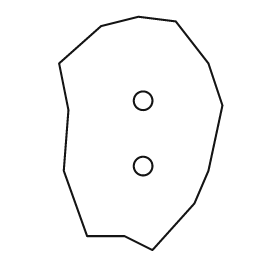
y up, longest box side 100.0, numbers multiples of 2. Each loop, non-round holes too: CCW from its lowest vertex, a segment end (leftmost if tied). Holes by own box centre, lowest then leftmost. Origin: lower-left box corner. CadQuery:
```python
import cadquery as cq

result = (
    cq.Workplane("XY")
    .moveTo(40.0, 0.0)
    .lineTo(58.0, 20.0)
    .lineTo(64.0, 34.0)
    .lineTo(70.0, 62.0)
    .lineTo(64.0, 80.0)
    .lineTo(50.0, 98.0)
    .lineTo(34.0, 100.0)
    .lineTo(18.0, 96.0)
    .lineTo(0.0, 80.0)
    .lineTo(4.0, 60.0)
    .lineTo(2.0, 34.0)
    .lineTo(12.0, 6.0)
    .lineTo(28.0, 6.0)
    .close()
    .moveTo(36.0, 36.0)
    .circle(4.0)
    .moveTo(36.0, 64.0)
    .circle(4.0)
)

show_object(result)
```